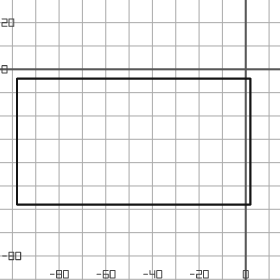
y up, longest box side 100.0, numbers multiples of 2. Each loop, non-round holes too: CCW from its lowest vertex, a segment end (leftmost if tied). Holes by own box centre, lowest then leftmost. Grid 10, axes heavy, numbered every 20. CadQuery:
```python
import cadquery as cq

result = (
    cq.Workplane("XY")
    .moveTo(-98.0, -58.0)
    .lineTo(2.0, -58.0)
    .lineTo(2.0, -4.0)
    .lineTo(-98.0, -4.0)
    .close()
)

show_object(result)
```